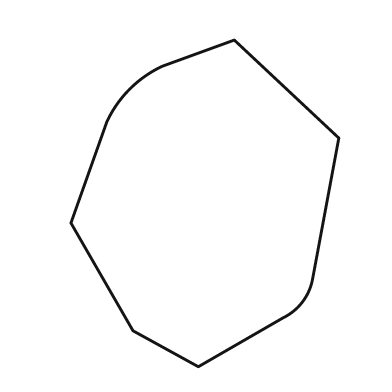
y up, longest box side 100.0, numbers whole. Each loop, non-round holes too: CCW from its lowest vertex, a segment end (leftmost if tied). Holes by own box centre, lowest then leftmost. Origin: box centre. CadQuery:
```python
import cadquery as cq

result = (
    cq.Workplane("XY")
    .moveTo(-2.0, -50.0)
    .lineTo(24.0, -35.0)
    .threePointArc((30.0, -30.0), (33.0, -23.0))
    .lineTo(41.0, 20.0)
    .lineTo(9.0, 50.0)
    .lineTo(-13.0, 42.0)
    .threePointArc((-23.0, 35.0), (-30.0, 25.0))
    .lineTo(-41.0, -6.0)
    .lineTo(-22.0, -39.0)
    .close()
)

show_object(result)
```